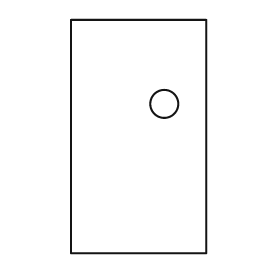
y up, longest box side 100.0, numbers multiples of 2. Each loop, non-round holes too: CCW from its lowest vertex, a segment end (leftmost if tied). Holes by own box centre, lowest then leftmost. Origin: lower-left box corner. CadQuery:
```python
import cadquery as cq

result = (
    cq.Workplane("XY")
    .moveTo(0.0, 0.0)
    .lineTo(58.0, 0.0)
    .lineTo(58.0, 100.0)
    .lineTo(0.0, 100.0)
    .close()
    .moveTo(40.0, 64.0)
    .circle(6.0)
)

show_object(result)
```